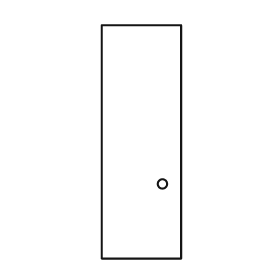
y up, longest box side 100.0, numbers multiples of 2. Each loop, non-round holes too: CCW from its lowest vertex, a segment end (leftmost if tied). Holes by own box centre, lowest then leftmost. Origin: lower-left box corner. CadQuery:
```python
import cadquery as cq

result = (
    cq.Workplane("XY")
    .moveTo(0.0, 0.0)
    .lineTo(34.0, 0.0)
    .lineTo(34.0, 100.0)
    .lineTo(0.0, 100.0)
    .close()
    .moveTo(26.0, 32.0)
    .circle(2.0)
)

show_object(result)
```